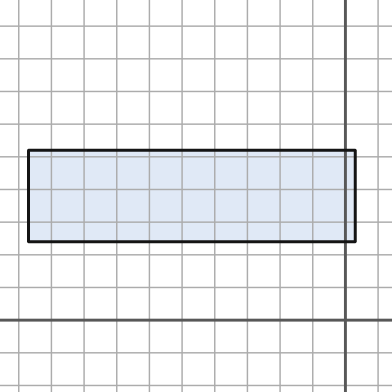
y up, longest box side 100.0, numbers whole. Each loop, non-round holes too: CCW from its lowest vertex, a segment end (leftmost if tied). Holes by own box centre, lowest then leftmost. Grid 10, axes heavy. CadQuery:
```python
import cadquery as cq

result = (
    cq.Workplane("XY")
    .moveTo(-97.0, 24.0)
    .lineTo(3.0, 24.0)
    .lineTo(3.0, 52.0)
    .lineTo(-97.0, 52.0)
    .close()
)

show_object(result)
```